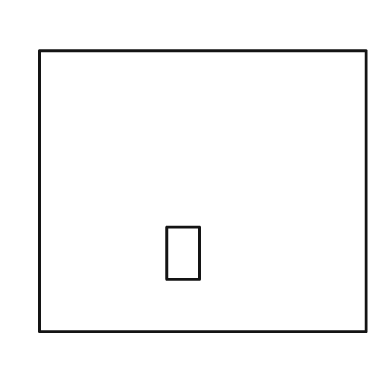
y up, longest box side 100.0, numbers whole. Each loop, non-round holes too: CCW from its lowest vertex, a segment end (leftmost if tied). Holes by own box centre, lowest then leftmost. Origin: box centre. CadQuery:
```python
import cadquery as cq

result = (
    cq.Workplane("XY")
    .moveTo(-50.0, -43.0)
    .lineTo(50.0, -43.0)
    .lineTo(50.0, 43.0)
    .lineTo(-50.0, 43.0)
    .close()
    .moveTo(-11.0, -27.0)
    .lineTo(-1.0, -27.0)
    .lineTo(-1.0, -11.0)
    .lineTo(-11.0, -11.0)
    .close()
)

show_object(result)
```